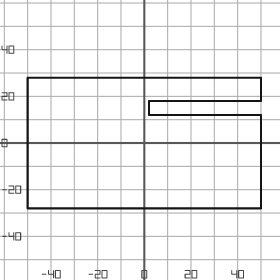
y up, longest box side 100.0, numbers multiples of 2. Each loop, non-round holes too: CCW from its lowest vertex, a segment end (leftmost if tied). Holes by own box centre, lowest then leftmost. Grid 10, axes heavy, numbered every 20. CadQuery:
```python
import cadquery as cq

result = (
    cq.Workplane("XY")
    .moveTo(-50.0, -28.0)
    .lineTo(50.0, -28.0)
    .lineTo(50.0, 12.0)
    .lineTo(2.0, 12.0)
    .lineTo(2.0, 18.0)
    .lineTo(50.0, 18.0)
    .lineTo(50.0, 28.0)
    .lineTo(-50.0, 28.0)
    .close()
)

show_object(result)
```